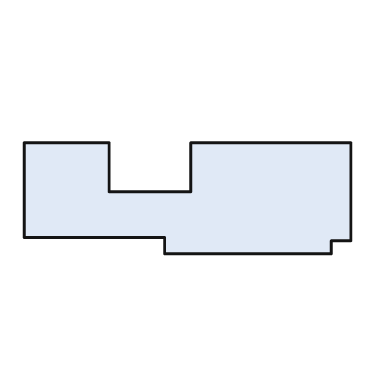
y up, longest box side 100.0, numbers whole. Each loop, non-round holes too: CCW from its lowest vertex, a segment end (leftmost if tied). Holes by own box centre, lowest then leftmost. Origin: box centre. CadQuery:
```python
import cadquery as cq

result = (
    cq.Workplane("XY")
    .moveTo(-7.0, -17.0)
    .lineTo(44.0, -17.0)
    .lineTo(44.0, -13.0)
    .lineTo(50.0, -13.0)
    .lineTo(50.0, 17.0)
    .lineTo(1.0, 17.0)
    .lineTo(1.0, 2.0)
    .lineTo(-24.0, 2.0)
    .lineTo(-24.0, 17.0)
    .lineTo(-50.0, 17.0)
    .lineTo(-50.0, -12.0)
    .lineTo(-7.0, -12.0)
    .close()
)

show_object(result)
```